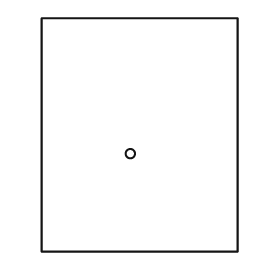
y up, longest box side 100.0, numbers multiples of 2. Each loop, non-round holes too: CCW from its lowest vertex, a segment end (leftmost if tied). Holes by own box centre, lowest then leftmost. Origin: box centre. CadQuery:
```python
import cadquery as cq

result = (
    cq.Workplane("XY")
    .moveTo(-42.0, -50.0)
    .lineTo(42.0, -50.0)
    .lineTo(42.0, 50.0)
    .lineTo(-42.0, 50.0)
    .close()
    .moveTo(-4.0, -8.0)
    .circle(2.0)
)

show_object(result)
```